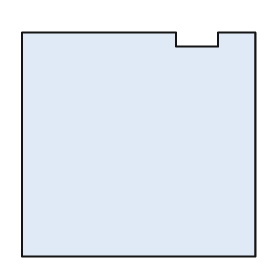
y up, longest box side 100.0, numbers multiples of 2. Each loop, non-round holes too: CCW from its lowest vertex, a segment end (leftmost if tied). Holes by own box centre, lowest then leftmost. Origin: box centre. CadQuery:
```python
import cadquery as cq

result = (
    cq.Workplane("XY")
    .moveTo(-50.0, -48.0)
    .lineTo(50.0, -48.0)
    .lineTo(50.0, 48.0)
    .lineTo(34.0, 48.0)
    .lineTo(34.0, 42.0)
    .lineTo(16.0, 42.0)
    .lineTo(16.0, 48.0)
    .lineTo(-50.0, 48.0)
    .close()
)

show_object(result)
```